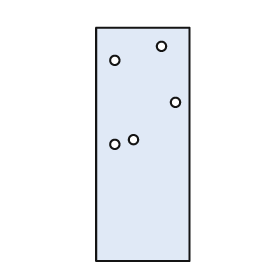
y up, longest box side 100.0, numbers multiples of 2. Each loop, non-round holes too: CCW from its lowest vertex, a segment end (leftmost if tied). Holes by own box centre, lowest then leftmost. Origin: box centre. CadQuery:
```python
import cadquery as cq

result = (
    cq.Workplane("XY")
    .moveTo(-20.0, -50.0)
    .lineTo(20.0, -50.0)
    .lineTo(20.0, 50.0)
    .lineTo(-20.0, 50.0)
    .close()
    .moveTo(-12.0, 0.0)
    .circle(2.0)
    .moveTo(-4.0, 2.0)
    .circle(2.0)
    .moveTo(14.0, 18.0)
    .circle(2.0)
    .moveTo(-12.0, 36.0)
    .circle(2.0)
    .moveTo(8.0, 42.0)
    .circle(2.0)
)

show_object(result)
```